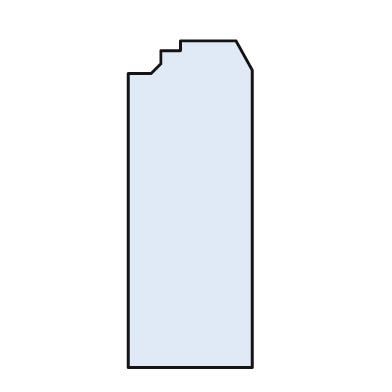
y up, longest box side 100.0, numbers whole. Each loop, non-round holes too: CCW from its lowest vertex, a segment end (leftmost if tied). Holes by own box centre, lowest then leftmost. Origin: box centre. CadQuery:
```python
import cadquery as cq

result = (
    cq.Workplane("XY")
    .moveTo(-19.0, -50.0)
    .lineTo(19.0, -50.0)
    .lineTo(19.0, 41.0)
    .lineTo(14.0, 50.0)
    .lineTo(-3.0, 50.0)
    .lineTo(-3.0, 47.0)
    .lineTo(-9.0, 47.0)
    .lineTo(-9.0, 43.0)
    .lineTo(-12.0, 40.0)
    .lineTo(-19.0, 40.0)
    .close()
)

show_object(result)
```